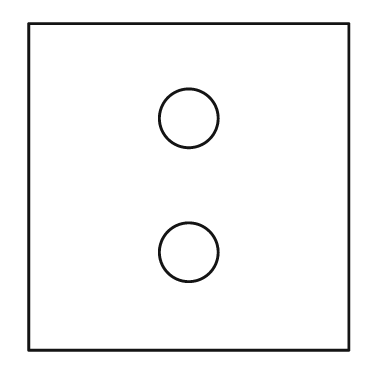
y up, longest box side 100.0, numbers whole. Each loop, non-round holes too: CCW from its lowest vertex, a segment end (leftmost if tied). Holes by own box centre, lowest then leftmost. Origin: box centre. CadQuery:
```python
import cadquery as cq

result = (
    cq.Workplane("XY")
    .moveTo(-49.0, -50.0)
    .lineTo(49.0, -50.0)
    .lineTo(49.0, 50.0)
    .lineTo(-49.0, 50.0)
    .close()
    .moveTo(0.0, -20.0)
    .circle(9.0)
    .moveTo(0.0, 21.0)
    .circle(9.0)
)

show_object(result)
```